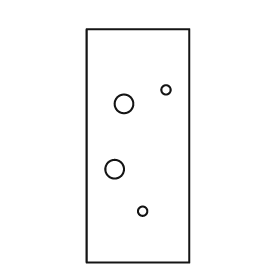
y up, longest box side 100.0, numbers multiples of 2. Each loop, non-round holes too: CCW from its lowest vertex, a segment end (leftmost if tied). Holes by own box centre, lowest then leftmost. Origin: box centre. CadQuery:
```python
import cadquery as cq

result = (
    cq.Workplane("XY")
    .moveTo(-22.0, -50.0)
    .lineTo(22.0, -50.0)
    .lineTo(22.0, 50.0)
    .lineTo(-22.0, 50.0)
    .close()
    .moveTo(2.0, -28.0)
    .circle(2.0)
    .moveTo(-10.0, -10.0)
    .circle(4.0)
    .moveTo(-6.0, 18.0)
    .circle(4.0)
    .moveTo(12.0, 24.0)
    .circle(2.0)
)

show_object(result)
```